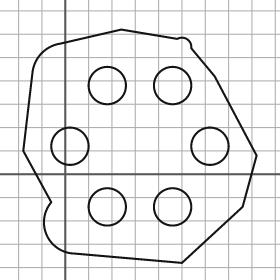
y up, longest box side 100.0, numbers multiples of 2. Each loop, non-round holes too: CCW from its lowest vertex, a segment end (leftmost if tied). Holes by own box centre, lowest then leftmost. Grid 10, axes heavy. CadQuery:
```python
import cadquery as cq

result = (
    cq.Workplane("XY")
    .moveTo(50.0, -38.0)
    .lineTo(76.0, -14.0)
    .lineTo(82.0, 8.0)
    .lineTo(64.0, 42.0)
    .lineTo(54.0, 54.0)
    .threePointArc((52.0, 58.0), (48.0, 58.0))
    .lineTo(24.0, 62.0)
    .lineTo(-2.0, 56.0)
    .threePointArc((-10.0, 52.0), (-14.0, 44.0))
    .lineTo(-18.0, 10.0)
    .lineTo(-6.0, -12.0)
    .threePointArc((-8.0, -26.0), (4.0, -34.0))
    .close()
    .moveTo(18.0, -14.0)
    .circle(8.0)
    .moveTo(46.0, -14.0)
    .circle(8.0)
    .moveTo(2.0, 12.0)
    .circle(8.0)
    .moveTo(62.0, 12.0)
    .circle(8.0)
    .moveTo(18.0, 38.0)
    .circle(8.0)
    .moveTo(46.0, 38.0)
    .circle(8.0)
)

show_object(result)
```